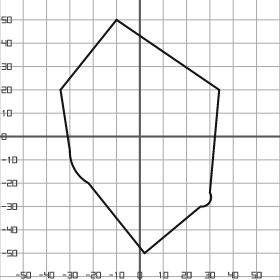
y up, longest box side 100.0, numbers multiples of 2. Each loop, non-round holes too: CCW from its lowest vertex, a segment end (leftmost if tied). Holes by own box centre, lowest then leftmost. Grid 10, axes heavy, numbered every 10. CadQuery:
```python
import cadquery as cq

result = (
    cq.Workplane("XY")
    .moveTo(2.0, -50.0)
    .lineTo(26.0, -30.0)
    .threePointArc((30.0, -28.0), (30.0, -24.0))
    .lineTo(34.0, 20.0)
    .lineTo(-10.0, 50.0)
    .lineTo(-34.0, 20.0)
    .lineTo(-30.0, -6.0)
    .threePointArc((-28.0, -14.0), (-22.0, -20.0))
    .close()
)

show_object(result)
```